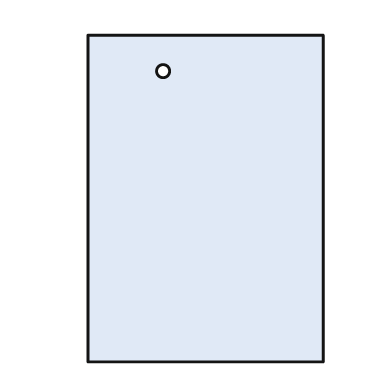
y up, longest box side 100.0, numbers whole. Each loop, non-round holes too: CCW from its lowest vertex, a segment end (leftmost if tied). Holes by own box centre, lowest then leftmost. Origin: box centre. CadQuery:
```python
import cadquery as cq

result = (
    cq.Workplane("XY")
    .moveTo(-36.0, -50.0)
    .lineTo(36.0, -50.0)
    .lineTo(36.0, 50.0)
    .lineTo(-36.0, 50.0)
    .close()
    .moveTo(-13.0, 39.0)
    .circle(2.0)
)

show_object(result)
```